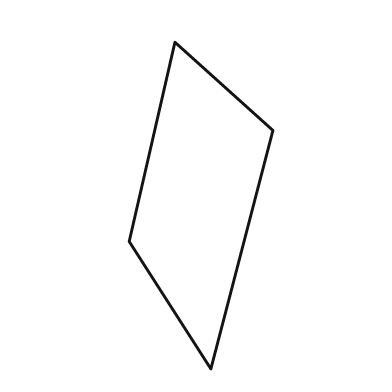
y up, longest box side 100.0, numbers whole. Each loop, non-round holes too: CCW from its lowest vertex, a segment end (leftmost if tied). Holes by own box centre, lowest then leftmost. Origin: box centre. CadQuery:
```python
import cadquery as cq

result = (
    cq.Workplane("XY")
    .moveTo(3.0, -50.0)
    .lineTo(22.0, 23.0)
    .lineTo(-8.0, 50.0)
    .lineTo(-22.0, -11.0)
    .close()
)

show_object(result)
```